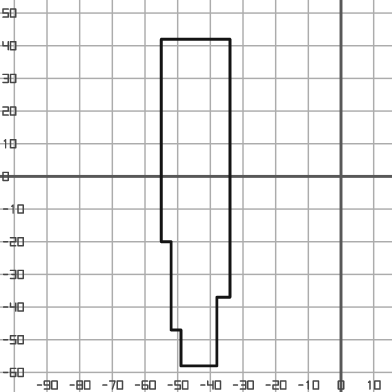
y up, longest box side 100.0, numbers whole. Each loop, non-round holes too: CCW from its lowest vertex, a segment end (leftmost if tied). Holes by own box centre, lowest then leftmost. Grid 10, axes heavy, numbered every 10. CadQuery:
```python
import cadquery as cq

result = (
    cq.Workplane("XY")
    .moveTo(-49.0, -58.0)
    .lineTo(-38.0, -58.0)
    .lineTo(-38.0, -37.0)
    .lineTo(-34.0, -37.0)
    .lineTo(-34.0, 42.0)
    .lineTo(-55.0, 42.0)
    .lineTo(-55.0, -20.0)
    .lineTo(-52.0, -20.0)
    .lineTo(-52.0, -47.0)
    .lineTo(-49.0, -47.0)
    .close()
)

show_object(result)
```